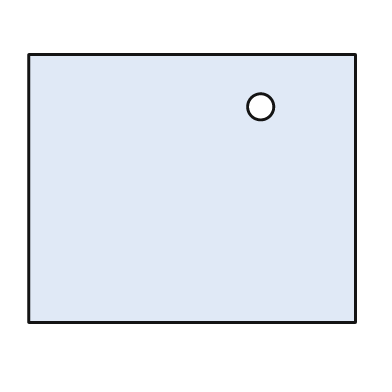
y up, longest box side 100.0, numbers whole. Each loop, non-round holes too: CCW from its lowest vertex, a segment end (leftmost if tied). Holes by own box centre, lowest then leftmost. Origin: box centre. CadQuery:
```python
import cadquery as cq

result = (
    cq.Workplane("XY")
    .moveTo(-50.0, -41.0)
    .lineTo(50.0, -41.0)
    .lineTo(50.0, 41.0)
    .lineTo(-50.0, 41.0)
    .close()
    .moveTo(21.0, 25.0)
    .circle(4.0)
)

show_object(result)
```